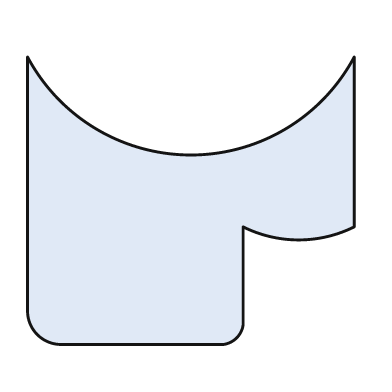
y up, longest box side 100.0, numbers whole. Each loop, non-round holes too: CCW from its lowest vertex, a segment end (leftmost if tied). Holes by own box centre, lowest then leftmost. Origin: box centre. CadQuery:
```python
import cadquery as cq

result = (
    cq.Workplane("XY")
    .moveTo(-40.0, -44.0)
    .lineTo(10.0, -44.0)
    .threePointArc((14.0, -42.0), (16.0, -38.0))
    .lineTo(16.0, -8.0)
    .threePointArc((33.0, -12.0), (50.0, -8.0))
    .lineTo(50.0, 44.0)
    .threePointArc((0.0, 14.0), (-50.0, 44.0))
    .lineTo(-50.0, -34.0)
    .threePointArc((-47.0, -41.0), (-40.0, -44.0))
    .close()
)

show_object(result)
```